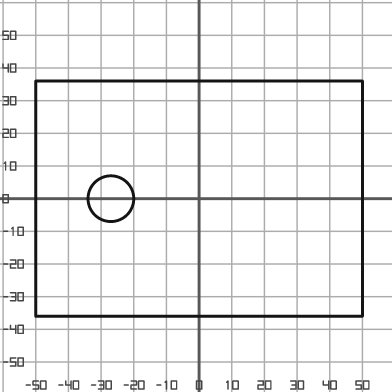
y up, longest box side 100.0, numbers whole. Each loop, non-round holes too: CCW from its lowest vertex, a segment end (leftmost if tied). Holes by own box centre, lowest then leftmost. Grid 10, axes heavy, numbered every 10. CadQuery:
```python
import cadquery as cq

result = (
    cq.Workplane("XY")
    .moveTo(-50.0, -36.0)
    .lineTo(50.0, -36.0)
    .lineTo(50.0, 36.0)
    .lineTo(-50.0, 36.0)
    .close()
    .moveTo(-27.0, 0.0)
    .circle(7.0)
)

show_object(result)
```